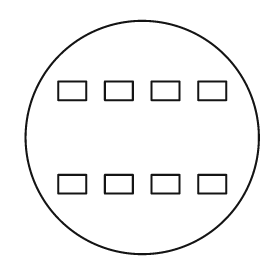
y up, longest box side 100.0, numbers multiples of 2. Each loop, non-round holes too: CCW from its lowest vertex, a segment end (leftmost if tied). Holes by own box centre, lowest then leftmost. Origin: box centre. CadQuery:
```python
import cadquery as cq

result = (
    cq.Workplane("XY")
    .moveTo(0.0, 0.0)
    .circle(50.0)
    .moveTo(-36.0, -24.0)
    .lineTo(-24.0, -24.0)
    .lineTo(-24.0, -16.0)
    .lineTo(-36.0, -16.0)
    .close()
    .moveTo(-16.0, -24.0)
    .lineTo(-4.0, -24.0)
    .lineTo(-4.0, -16.0)
    .lineTo(-16.0, -16.0)
    .close()
    .moveTo(4.0, -24.0)
    .lineTo(16.0, -24.0)
    .lineTo(16.0, -16.0)
    .lineTo(4.0, -16.0)
    .close()
    .moveTo(24.0, -24.0)
    .lineTo(36.0, -24.0)
    .lineTo(36.0, -16.0)
    .lineTo(24.0, -16.0)
    .close()
    .moveTo(-36.0, 16.0)
    .lineTo(-24.0, 16.0)
    .lineTo(-24.0, 24.0)
    .lineTo(-36.0, 24.0)
    .close()
    .moveTo(-16.0, 16.0)
    .lineTo(-4.0, 16.0)
    .lineTo(-4.0, 24.0)
    .lineTo(-16.0, 24.0)
    .close()
    .moveTo(4.0, 16.0)
    .lineTo(16.0, 16.0)
    .lineTo(16.0, 24.0)
    .lineTo(4.0, 24.0)
    .close()
    .moveTo(24.0, 16.0)
    .lineTo(36.0, 16.0)
    .lineTo(36.0, 24.0)
    .lineTo(24.0, 24.0)
    .close()
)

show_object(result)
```